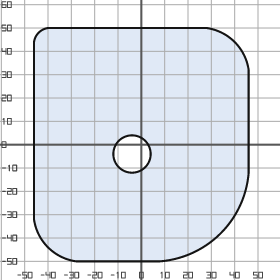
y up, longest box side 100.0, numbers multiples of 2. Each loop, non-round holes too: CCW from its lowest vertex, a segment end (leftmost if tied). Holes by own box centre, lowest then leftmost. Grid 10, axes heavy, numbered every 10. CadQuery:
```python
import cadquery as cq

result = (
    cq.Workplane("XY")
    .moveTo(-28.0, -50.0)
    .lineTo(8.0, -50.0)
    .threePointArc((34.0, -38.0), (46.0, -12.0))
    .lineTo(46.0, 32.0)
    .threePointArc((40.0, 44.0), (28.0, 50.0))
    .lineTo(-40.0, 50.0)
    .threePointArc((-44.0, 48.0), (-46.0, 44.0))
    .lineTo(-46.0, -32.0)
    .threePointArc((-40.0, -44.0), (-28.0, -50.0))
    .close()
    .moveTo(-4.0, -4.0)
    .circle(8.0)
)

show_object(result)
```